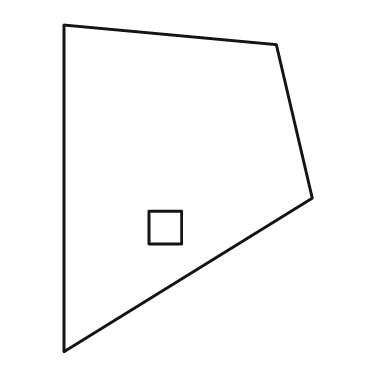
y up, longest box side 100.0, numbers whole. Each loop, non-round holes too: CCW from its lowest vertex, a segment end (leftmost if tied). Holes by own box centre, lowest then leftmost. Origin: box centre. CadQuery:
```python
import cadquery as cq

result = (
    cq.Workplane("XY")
    .moveTo(-38.0, -50.0)
    .lineTo(38.0, -3.0)
    .lineTo(27.0, 44.0)
    .lineTo(-38.0, 50.0)
    .close()
    .moveTo(-12.0, -17.0)
    .lineTo(-2.0, -17.0)
    .lineTo(-2.0, -7.0)
    .lineTo(-12.0, -7.0)
    .close()
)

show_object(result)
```